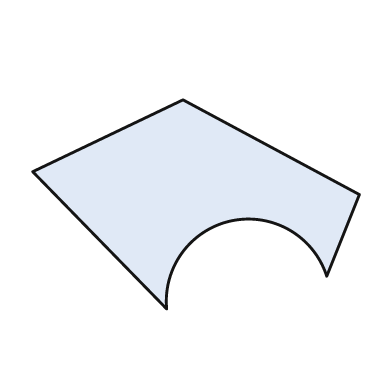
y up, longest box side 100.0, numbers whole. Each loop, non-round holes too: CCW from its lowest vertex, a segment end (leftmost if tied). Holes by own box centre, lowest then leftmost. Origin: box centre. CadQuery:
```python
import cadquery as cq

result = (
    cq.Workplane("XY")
    .moveTo(-9.0, -32.0)
    .threePointArc((11.0, -5.0), (40.0, -22.0))
    .lineTo(50.0, 3.0)
    .lineTo(-4.0, 32.0)
    .lineTo(-50.0, 10.0)
    .close()
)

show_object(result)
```